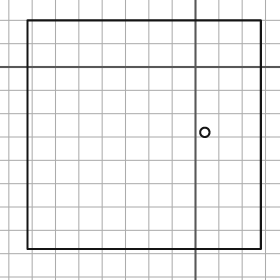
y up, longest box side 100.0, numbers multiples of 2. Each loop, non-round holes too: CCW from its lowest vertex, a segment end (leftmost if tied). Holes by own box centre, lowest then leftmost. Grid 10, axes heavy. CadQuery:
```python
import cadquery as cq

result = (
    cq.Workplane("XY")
    .moveTo(-72.0, -78.0)
    .lineTo(28.0, -78.0)
    .lineTo(28.0, 20.0)
    .lineTo(-72.0, 20.0)
    .close()
    .moveTo(4.0, -28.0)
    .circle(2.0)
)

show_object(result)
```